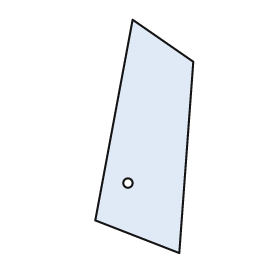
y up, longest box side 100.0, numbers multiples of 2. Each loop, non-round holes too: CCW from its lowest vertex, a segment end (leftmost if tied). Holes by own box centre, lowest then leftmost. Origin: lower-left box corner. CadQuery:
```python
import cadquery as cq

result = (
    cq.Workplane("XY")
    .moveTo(36.0, 0.0)
    .lineTo(42.0, 82.0)
    .lineTo(16.0, 100.0)
    .lineTo(0.0, 14.0)
    .close()
    .moveTo(14.0, 30.0)
    .circle(2.0)
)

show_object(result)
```